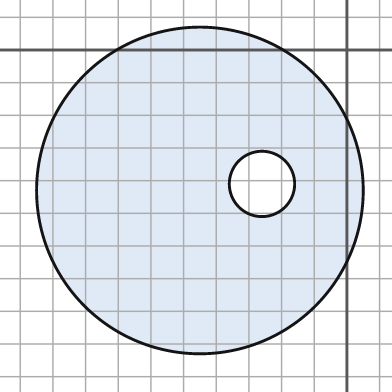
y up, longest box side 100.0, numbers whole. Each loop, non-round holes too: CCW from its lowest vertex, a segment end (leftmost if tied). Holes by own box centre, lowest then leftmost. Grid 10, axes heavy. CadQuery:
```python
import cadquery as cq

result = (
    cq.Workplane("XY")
    .moveTo(-45.0, -43.0)
    .circle(50.0)
    .moveTo(-26.0, -41.0)
    .circle(10.0)
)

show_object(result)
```